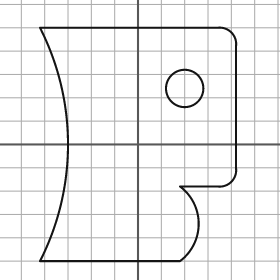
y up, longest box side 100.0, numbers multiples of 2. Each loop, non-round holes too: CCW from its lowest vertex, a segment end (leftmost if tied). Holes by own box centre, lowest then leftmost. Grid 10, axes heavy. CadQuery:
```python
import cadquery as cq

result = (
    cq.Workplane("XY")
    .moveTo(-42.0, -50.0)
    .lineTo(18.0, -50.0)
    .threePointArc((26.0, -34.0), (18.0, -18.0))
    .lineTo(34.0, -18.0)
    .threePointArc((40.0, -16.0), (42.0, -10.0))
    .lineTo(42.0, 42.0)
    .threePointArc((40.0, 48.0), (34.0, 50.0))
    .lineTo(-42.0, 50.0)
    .threePointArc((-30.0, 0.0), (-42.0, -50.0))
    .close()
    .moveTo(20.0, 24.0)
    .circle(8.0)
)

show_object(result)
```